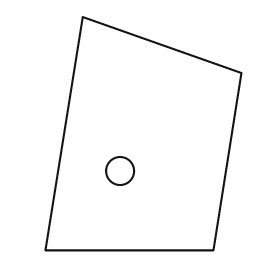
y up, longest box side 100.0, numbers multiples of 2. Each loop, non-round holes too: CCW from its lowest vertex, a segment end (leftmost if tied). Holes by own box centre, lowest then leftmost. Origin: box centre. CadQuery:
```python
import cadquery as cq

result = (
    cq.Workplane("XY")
    .moveTo(-42.0, -50.0)
    .lineTo(30.0, -50.0)
    .lineTo(42.0, 26.0)
    .lineTo(-26.0, 50.0)
    .close()
    .moveTo(-10.0, -16.0)
    .circle(6.0)
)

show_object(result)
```